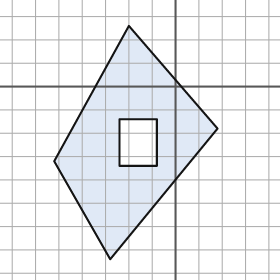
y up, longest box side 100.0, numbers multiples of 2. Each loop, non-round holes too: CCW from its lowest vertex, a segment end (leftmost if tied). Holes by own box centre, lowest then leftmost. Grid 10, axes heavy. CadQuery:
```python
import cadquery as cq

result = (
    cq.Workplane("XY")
    .moveTo(-28.0, -74.0)
    .lineTo(18.0, -18.0)
    .lineTo(-20.0, 26.0)
    .lineTo(-52.0, -32.0)
    .close()
    .moveTo(-24.0, -34.0)
    .lineTo(-8.0, -34.0)
    .lineTo(-8.0, -14.0)
    .lineTo(-24.0, -14.0)
    .close()
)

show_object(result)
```